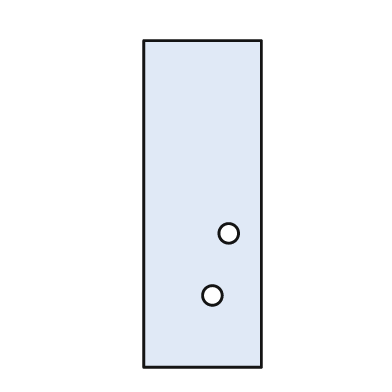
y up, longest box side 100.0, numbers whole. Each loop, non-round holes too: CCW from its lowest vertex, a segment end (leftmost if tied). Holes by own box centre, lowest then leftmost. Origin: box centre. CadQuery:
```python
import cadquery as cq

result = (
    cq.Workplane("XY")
    .moveTo(-18.0, -50.0)
    .lineTo(18.0, -50.0)
    .lineTo(18.0, 50.0)
    .lineTo(-18.0, 50.0)
    .close()
    .moveTo(3.0, -28.0)
    .circle(3.0)
    .moveTo(8.0, -9.0)
    .circle(3.0)
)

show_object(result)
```